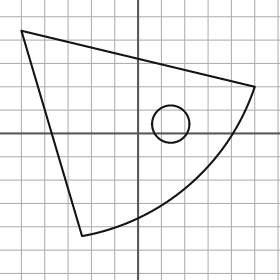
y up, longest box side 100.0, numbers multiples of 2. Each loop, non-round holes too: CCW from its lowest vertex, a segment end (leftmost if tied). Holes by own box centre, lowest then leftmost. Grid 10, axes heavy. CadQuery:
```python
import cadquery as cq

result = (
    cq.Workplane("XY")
    .moveTo(-24.0, -44.0)
    .threePointArc((22.0, -22.0), (50.0, 20.0))
    .lineTo(-50.0, 44.0)
    .close()
    .moveTo(14.0, 4.0)
    .circle(8.0)
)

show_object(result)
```